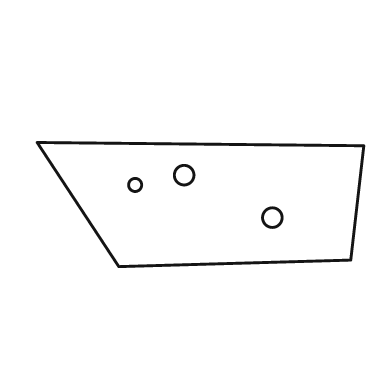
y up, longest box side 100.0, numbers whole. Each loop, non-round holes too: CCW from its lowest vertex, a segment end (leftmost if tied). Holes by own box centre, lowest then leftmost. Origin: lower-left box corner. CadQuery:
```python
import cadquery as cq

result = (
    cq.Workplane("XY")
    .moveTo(25.0, 0.0)
    .lineTo(96.0, 2.0)
    .lineTo(100.0, 37.0)
    .lineTo(0.0, 38.0)
    .close()
    .moveTo(72.0, 15.0)
    .circle(3.0)
    .moveTo(30.0, 25.0)
    .circle(2.0)
    .moveTo(45.0, 28.0)
    .circle(3.0)
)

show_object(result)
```